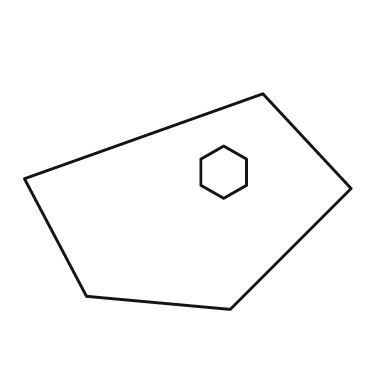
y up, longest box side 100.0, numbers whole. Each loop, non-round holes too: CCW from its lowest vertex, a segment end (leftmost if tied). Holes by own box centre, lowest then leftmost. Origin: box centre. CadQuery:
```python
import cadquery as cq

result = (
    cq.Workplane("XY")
    .moveTo(13.0, -33.0)
    .lineTo(50.0, 4.0)
    .lineTo(23.0, 33.0)
    .lineTo(-50.0, 7.0)
    .lineTo(-31.0, -29.0)
    .close()
    .moveTo(11.0, 1.0)
    .lineTo(18.0, 5.0)
    .lineTo(18.0, 13.0)
    .lineTo(11.0, 17.0)
    .lineTo(4.0, 13.0)
    .lineTo(4.0, 5.0)
    .close()
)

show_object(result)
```